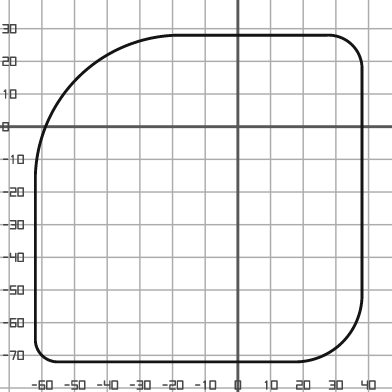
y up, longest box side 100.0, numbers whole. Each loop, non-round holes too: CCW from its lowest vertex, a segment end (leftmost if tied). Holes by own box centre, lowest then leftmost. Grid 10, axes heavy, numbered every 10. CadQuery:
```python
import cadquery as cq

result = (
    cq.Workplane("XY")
    .moveTo(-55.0, -72.0)
    .lineTo(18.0, -72.0)
    .threePointArc((32.0, -66.0), (38.0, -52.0))
    .lineTo(38.0, 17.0)
    .threePointArc((35.0, 25.0), (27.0, 28.0))
    .lineTo(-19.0, 28.0)
    .threePointArc((-49.0, 15.0), (-62.0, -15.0))
    .lineTo(-62.0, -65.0)
    .threePointArc((-60.0, -70.0), (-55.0, -72.0))
    .close()
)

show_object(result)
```